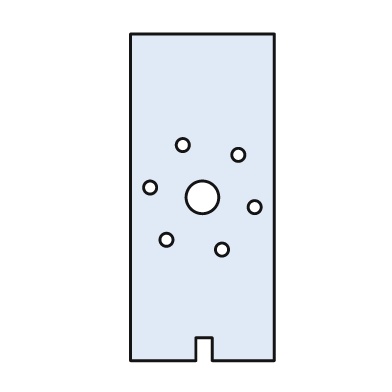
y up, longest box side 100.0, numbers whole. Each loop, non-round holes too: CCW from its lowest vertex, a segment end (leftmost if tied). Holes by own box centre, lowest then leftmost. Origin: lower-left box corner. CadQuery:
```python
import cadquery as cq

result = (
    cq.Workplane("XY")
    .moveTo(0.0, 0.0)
    .lineTo(20.0, 0.0)
    .lineTo(20.0, 7.0)
    .lineTo(25.0, 7.0)
    .lineTo(25.0, 0.0)
    .lineTo(44.0, 0.0)
    .lineTo(44.0, 100.0)
    .lineTo(0.0, 100.0)
    .close()
    .moveTo(28.0, 34.0)
    .circle(2.0)
    .moveTo(11.0, 37.0)
    .circle(2.0)
    .moveTo(38.0, 47.0)
    .circle(2.0)
    .moveTo(22.0, 50.0)
    .circle(5.0)
    .moveTo(6.0, 53.0)
    .circle(2.0)
    .moveTo(33.0, 63.0)
    .circle(2.0)
    .moveTo(16.0, 66.0)
    .circle(2.0)
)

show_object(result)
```